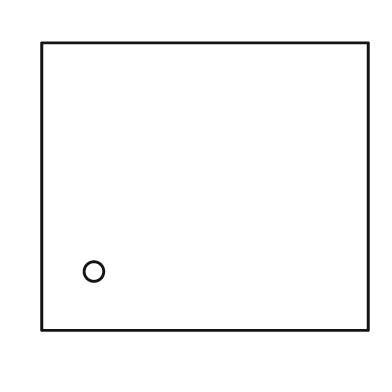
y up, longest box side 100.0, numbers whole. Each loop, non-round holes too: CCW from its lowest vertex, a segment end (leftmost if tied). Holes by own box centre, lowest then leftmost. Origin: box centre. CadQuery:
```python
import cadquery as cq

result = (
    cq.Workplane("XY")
    .moveTo(-50.0, -44.0)
    .lineTo(50.0, -44.0)
    .lineTo(50.0, 44.0)
    .lineTo(-50.0, 44.0)
    .close()
    .moveTo(-34.0, -26.0)
    .circle(3.0)
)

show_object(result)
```